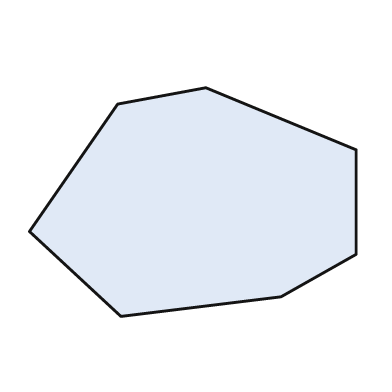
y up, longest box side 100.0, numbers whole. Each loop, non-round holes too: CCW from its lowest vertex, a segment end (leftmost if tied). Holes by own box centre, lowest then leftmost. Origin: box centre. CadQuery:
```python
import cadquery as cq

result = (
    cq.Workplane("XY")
    .moveTo(-22.0, -35.0)
    .lineTo(27.0, -29.0)
    .lineTo(50.0, -16.0)
    .lineTo(50.0, 16.0)
    .lineTo(4.0, 35.0)
    .lineTo(-23.0, 30.0)
    .lineTo(-50.0, -9.0)
    .close()
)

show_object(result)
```